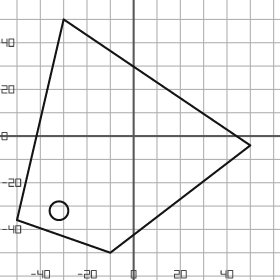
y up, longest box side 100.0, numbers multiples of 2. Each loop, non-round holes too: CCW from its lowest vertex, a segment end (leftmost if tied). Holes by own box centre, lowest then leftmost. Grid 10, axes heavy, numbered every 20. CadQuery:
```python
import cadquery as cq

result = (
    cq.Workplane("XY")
    .moveTo(-10.0, -50.0)
    .lineTo(50.0, -4.0)
    .lineTo(-30.0, 50.0)
    .lineTo(-50.0, -36.0)
    .close()
    .moveTo(-32.0, -32.0)
    .circle(4.0)
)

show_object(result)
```